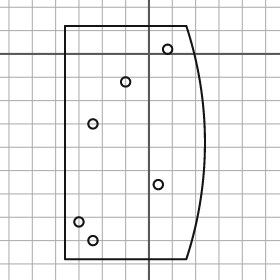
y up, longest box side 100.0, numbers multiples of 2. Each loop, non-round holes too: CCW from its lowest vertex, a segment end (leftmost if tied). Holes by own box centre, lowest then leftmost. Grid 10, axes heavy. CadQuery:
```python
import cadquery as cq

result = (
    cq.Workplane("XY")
    .moveTo(-36.0, -88.0)
    .lineTo(16.0, -88.0)
    .threePointArc((24.0, -38.0), (16.0, 12.0))
    .lineTo(-36.0, 12.0)
    .close()
    .moveTo(-24.0, -80.0)
    .circle(2.0)
    .moveTo(-30.0, -72.0)
    .circle(2.0)
    .moveTo(4.0, -56.0)
    .circle(2.0)
    .moveTo(-24.0, -30.0)
    .circle(2.0)
    .moveTo(-10.0, -12.0)
    .circle(2.0)
    .moveTo(8.0, 2.0)
    .circle(2.0)
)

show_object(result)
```